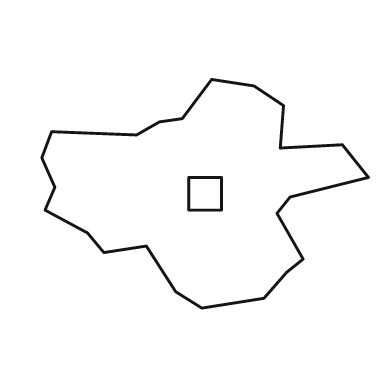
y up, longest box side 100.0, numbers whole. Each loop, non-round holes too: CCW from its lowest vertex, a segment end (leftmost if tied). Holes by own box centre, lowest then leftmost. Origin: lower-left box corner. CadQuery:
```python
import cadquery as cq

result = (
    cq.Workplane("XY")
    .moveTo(49.0, 0.0)
    .lineTo(68.0, 3.0)
    .lineTo(75.0, 11.0)
    .lineTo(80.0, 15.0)
    .lineTo(72.0, 29.0)
    .lineTo(76.0, 34.0)
    .lineTo(100.0, 40.0)
    .lineTo(92.0, 50.0)
    .lineTo(73.0, 49.0)
    .lineTo(74.0, 62.0)
    .lineTo(65.0, 68.0)
    .lineTo(52.0, 70.0)
    .lineTo(43.0, 58.0)
    .lineTo(36.0, 57.0)
    .lineTo(29.0, 53.0)
    .lineTo(3.0, 54.0)
    .lineTo(0.0, 46.0)
    .lineTo(4.0, 37.0)
    .lineTo(1.0, 30.0)
    .lineTo(14.0, 23.0)
    .lineTo(19.0, 17.0)
    .lineTo(32.0, 19.0)
    .lineTo(41.0, 5.0)
    .close()
    .moveTo(45.0, 30.0)
    .lineTo(55.0, 30.0)
    .lineTo(55.0, 40.0)
    .lineTo(45.0, 40.0)
    .close()
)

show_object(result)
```